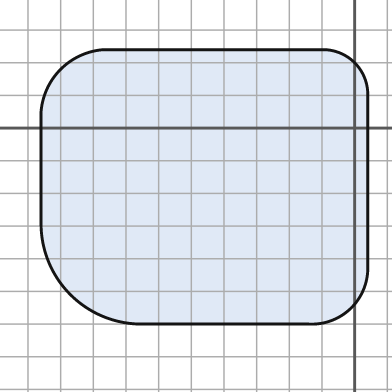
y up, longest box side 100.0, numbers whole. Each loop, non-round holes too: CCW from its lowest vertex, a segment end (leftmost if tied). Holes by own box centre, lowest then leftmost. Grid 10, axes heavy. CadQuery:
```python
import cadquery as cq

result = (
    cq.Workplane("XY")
    .moveTo(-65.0, -60.0)
    .lineTo(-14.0, -60.0)
    .threePointArc((-1.0, -55.0), (4.0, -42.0))
    .lineTo(4.0, 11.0)
    .threePointArc((0.0, 20.0), (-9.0, 24.0))
    .lineTo(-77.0, 24.0)
    .threePointArc((-90.0, 18.0), (-96.0, 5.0))
    .lineTo(-96.0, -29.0)
    .threePointArc((-87.0, -51.0), (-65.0, -60.0))
    .close()
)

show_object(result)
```